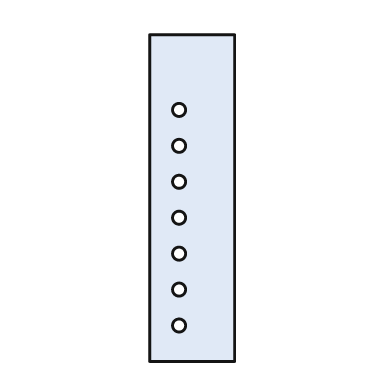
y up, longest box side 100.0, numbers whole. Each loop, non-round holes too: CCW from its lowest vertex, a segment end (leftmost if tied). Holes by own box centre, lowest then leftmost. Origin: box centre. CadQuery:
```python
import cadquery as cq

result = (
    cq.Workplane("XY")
    .moveTo(-13.0, -50.0)
    .lineTo(13.0, -50.0)
    .lineTo(13.0, 50.0)
    .lineTo(-13.0, 50.0)
    .close()
    .moveTo(-4.0, -39.0)
    .circle(2.0)
    .moveTo(-4.0, -28.0)
    .circle(2.0)
    .moveTo(-4.0, -17.0)
    .circle(2.0)
    .moveTo(-4.0, -6.0)
    .circle(2.0)
    .moveTo(-4.0, 5.0)
    .circle(2.0)
    .moveTo(-4.0, 16.0)
    .circle(2.0)
    .moveTo(-4.0, 27.0)
    .circle(2.0)
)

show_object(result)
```